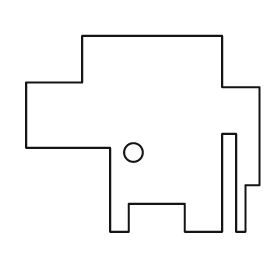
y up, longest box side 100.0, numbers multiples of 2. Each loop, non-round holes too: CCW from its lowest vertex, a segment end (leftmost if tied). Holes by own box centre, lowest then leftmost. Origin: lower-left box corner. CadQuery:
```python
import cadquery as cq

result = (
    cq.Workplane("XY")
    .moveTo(36.0, 0.0)
    .lineTo(44.0, 0.0)
    .lineTo(44.0, 12.0)
    .lineTo(68.0, 12.0)
    .lineTo(68.0, 0.0)
    .lineTo(84.0, 0.0)
    .lineTo(84.0, 42.0)
    .lineTo(90.0, 42.0)
    .lineTo(90.0, 0.0)
    .lineTo(94.0, 0.0)
    .lineTo(94.0, 20.0)
    .lineTo(100.0, 20.0)
    .lineTo(100.0, 62.0)
    .lineTo(84.0, 62.0)
    .lineTo(84.0, 84.0)
    .lineTo(24.0, 84.0)
    .lineTo(24.0, 64.0)
    .lineTo(0.0, 64.0)
    .lineTo(0.0, 36.0)
    .lineTo(36.0, 36.0)
    .close()
    .moveTo(46.0, 34.0)
    .circle(4.0)
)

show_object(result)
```